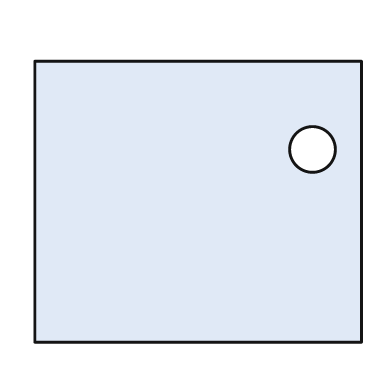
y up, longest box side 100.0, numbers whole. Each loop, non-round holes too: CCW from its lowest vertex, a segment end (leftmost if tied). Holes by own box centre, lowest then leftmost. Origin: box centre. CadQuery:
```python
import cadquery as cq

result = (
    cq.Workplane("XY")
    .moveTo(-50.0, -43.0)
    .lineTo(50.0, -43.0)
    .lineTo(50.0, 43.0)
    .lineTo(-50.0, 43.0)
    .close()
    .moveTo(35.0, 16.0)
    .circle(7.0)
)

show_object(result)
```